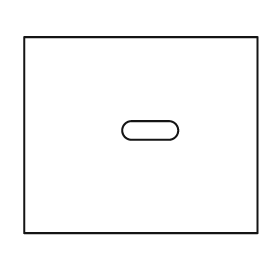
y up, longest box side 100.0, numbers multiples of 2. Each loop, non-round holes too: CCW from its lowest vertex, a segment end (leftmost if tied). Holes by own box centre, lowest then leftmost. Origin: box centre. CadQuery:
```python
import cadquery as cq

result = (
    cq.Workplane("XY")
    .moveTo(-50.0, -42.0)
    .lineTo(50.0, -42.0)
    .lineTo(50.0, 42.0)
    .lineTo(-50.0, 42.0)
    .close()
    .moveTo(-4.0, -2.0)
    .lineTo(12.0, -2.0)
    .threePointArc((16.0, 2.0), (12.0, 6.0))
    .lineTo(-4.0, 6.0)
    .threePointArc((-8.0, 2.0), (-4.0, -2.0))
    .close()
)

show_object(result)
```